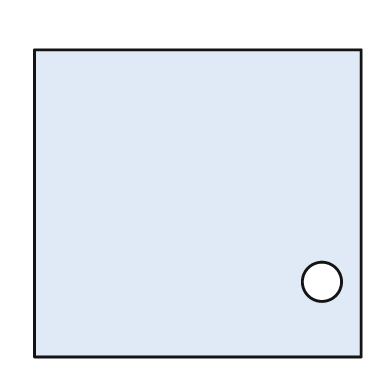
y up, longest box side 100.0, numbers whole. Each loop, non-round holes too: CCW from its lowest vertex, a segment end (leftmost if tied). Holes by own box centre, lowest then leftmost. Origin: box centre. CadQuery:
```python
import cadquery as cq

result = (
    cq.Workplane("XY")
    .moveTo(-50.0, -47.0)
    .lineTo(50.0, -47.0)
    .lineTo(50.0, 47.0)
    .lineTo(-50.0, 47.0)
    .close()
    .moveTo(38.0, -24.0)
    .circle(6.0)
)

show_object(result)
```